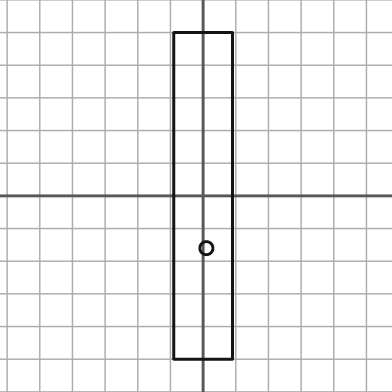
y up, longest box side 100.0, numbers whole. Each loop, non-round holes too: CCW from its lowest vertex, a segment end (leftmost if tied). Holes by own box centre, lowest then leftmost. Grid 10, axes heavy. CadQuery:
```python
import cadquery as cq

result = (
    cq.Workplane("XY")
    .moveTo(-9.0, -50.0)
    .lineTo(9.0, -50.0)
    .lineTo(9.0, 50.0)
    .lineTo(-9.0, 50.0)
    .close()
    .moveTo(1.0, -16.0)
    .circle(2.0)
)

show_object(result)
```